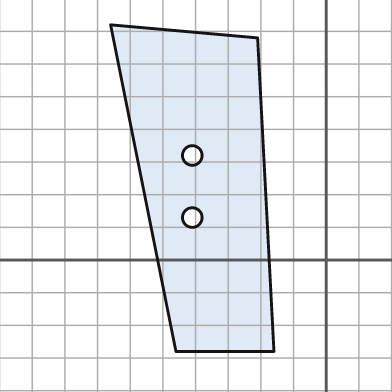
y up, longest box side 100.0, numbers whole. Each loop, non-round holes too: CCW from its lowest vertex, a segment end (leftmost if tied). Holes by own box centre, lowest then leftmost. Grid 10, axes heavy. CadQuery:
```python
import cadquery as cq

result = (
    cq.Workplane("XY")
    .moveTo(-46.0, -28.0)
    .lineTo(-16.0, -28.0)
    .lineTo(-21.0, 68.0)
    .lineTo(-66.0, 72.0)
    .close()
    .moveTo(-41.0, 13.0)
    .circle(3.0)
    .moveTo(-41.0, 32.0)
    .circle(3.0)
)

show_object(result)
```